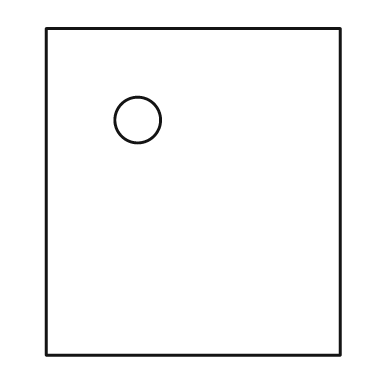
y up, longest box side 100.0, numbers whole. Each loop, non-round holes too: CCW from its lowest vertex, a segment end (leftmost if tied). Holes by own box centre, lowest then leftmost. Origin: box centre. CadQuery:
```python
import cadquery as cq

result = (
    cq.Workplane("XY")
    .moveTo(-45.0, -50.0)
    .lineTo(45.0, -50.0)
    .lineTo(45.0, 50.0)
    .lineTo(-45.0, 50.0)
    .close()
    .moveTo(-17.0, 22.0)
    .circle(7.0)
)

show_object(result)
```